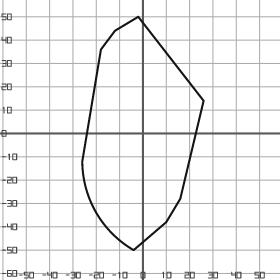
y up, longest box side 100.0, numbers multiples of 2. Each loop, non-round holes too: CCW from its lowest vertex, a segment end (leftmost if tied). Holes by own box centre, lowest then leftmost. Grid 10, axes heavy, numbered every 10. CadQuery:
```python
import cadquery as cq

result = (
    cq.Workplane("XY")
    .moveTo(-4.0, -50.0)
    .lineTo(10.0, -38.0)
    .lineTo(16.0, -28.0)
    .lineTo(26.0, 14.0)
    .lineTo(-2.0, 50.0)
    .lineTo(-12.0, 44.0)
    .lineTo(-18.0, 36.0)
    .lineTo(-26.0, -12.0)
    .threePointArc((-20.0, -34.0), (-4.0, -50.0))
    .close()
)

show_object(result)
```